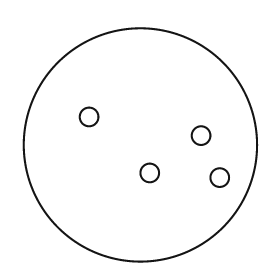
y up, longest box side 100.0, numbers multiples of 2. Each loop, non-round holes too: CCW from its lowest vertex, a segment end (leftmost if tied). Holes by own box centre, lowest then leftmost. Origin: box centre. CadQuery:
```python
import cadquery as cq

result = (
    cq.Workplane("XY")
    .moveTo(0.0, 0.0)
    .circle(50.0)
    .moveTo(34.0, -14.0)
    .circle(4.0)
    .moveTo(4.0, -12.0)
    .circle(4.0)
    .moveTo(26.0, 4.0)
    .circle(4.0)
    .moveTo(-22.0, 12.0)
    .circle(4.0)
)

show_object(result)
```